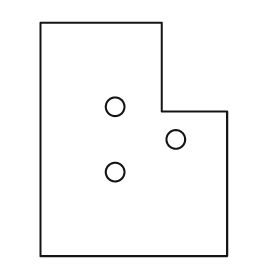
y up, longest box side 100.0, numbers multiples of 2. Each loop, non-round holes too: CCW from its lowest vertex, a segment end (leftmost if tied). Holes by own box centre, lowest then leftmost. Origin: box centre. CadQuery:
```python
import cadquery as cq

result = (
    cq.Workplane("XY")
    .moveTo(-40.0, -50.0)
    .lineTo(40.0, -50.0)
    .lineTo(40.0, 12.0)
    .lineTo(12.0, 12.0)
    .lineTo(12.0, 50.0)
    .lineTo(-40.0, 50.0)
    .close()
    .moveTo(-8.0, -14.0)
    .circle(4.0)
    .moveTo(18.0, 0.0)
    .circle(4.0)
    .moveTo(-8.0, 14.0)
    .circle(4.0)
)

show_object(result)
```